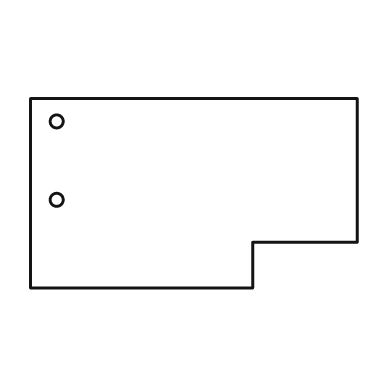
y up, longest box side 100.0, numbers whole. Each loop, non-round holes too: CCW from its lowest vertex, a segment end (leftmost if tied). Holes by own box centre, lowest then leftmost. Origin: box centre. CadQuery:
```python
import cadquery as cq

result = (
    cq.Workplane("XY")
    .moveTo(-50.0, -29.0)
    .lineTo(18.0, -29.0)
    .lineTo(18.0, -15.0)
    .lineTo(50.0, -15.0)
    .lineTo(50.0, 29.0)
    .lineTo(-50.0, 29.0)
    .close()
    .moveTo(-42.0, -2.0)
    .circle(2.0)
    .moveTo(-42.0, 22.0)
    .circle(2.0)
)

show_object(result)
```